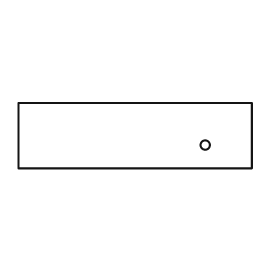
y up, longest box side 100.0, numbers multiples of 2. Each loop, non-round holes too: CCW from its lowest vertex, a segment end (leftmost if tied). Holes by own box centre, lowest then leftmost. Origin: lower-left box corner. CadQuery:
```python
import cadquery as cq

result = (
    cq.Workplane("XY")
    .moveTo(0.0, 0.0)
    .lineTo(100.0, 0.0)
    .lineTo(100.0, 28.0)
    .lineTo(0.0, 28.0)
    .close()
    .moveTo(80.0, 10.0)
    .circle(2.0)
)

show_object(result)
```